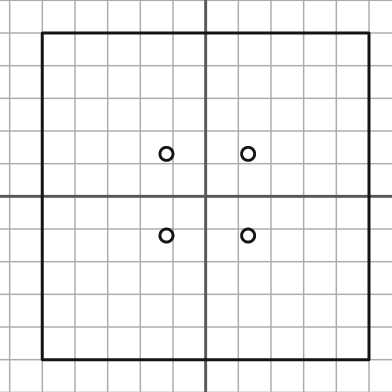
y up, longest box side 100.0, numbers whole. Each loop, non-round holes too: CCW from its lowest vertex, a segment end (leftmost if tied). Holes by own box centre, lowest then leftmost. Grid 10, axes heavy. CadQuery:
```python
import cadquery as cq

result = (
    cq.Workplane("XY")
    .moveTo(-50.0, -50.0)
    .lineTo(50.0, -50.0)
    .lineTo(50.0, 50.0)
    .lineTo(-50.0, 50.0)
    .close()
    .moveTo(-12.0, -12.0)
    .circle(2.0)
    .moveTo(13.0, -12.0)
    .circle(2.0)
    .moveTo(-12.0, 13.0)
    .circle(2.0)
    .moveTo(13.0, 13.0)
    .circle(2.0)
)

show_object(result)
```